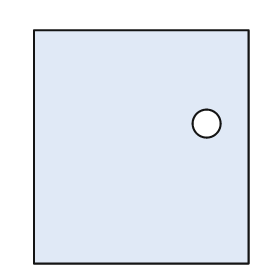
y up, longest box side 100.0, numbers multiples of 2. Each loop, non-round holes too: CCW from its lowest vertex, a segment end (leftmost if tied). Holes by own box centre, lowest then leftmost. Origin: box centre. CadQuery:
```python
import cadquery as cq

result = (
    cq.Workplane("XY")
    .moveTo(-46.0, -50.0)
    .lineTo(46.0, -50.0)
    .lineTo(46.0, 50.0)
    .lineTo(-46.0, 50.0)
    .close()
    .moveTo(28.0, 10.0)
    .circle(6.0)
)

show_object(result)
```